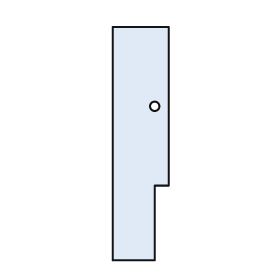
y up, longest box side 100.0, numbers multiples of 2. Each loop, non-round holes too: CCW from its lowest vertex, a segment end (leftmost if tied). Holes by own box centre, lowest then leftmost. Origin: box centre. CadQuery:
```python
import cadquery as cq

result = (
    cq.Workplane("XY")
    .moveTo(-12.0, -50.0)
    .lineTo(6.0, -50.0)
    .lineTo(6.0, -18.0)
    .lineTo(12.0, -18.0)
    .lineTo(12.0, 50.0)
    .lineTo(-12.0, 50.0)
    .close()
    .moveTo(6.0, 16.0)
    .circle(2.0)
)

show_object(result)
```